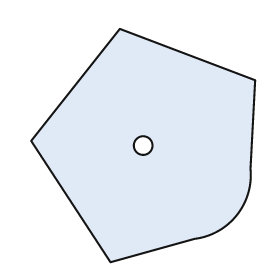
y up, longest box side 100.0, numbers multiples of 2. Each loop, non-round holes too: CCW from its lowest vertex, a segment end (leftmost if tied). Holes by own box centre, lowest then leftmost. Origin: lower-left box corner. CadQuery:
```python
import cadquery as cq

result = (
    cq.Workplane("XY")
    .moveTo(34.0, 0.0)
    .lineTo(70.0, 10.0)
    .threePointArc((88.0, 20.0), (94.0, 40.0))
    .lineTo(96.0, 78.0)
    .lineTo(38.0, 100.0)
    .lineTo(0.0, 52.0)
    .close()
    .moveTo(48.0, 50.0)
    .circle(4.0)
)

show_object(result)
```